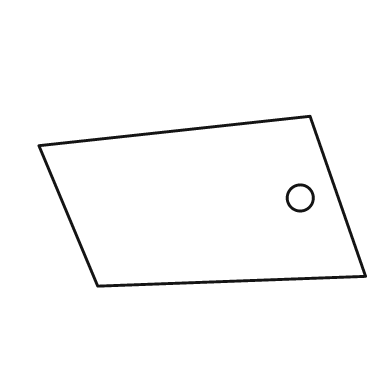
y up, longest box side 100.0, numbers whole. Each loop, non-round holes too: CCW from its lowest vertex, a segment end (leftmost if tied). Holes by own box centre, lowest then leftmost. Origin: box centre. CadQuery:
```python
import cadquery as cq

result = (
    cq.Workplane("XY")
    .moveTo(-32.0, -26.0)
    .lineTo(50.0, -23.0)
    .lineTo(33.0, 26.0)
    .lineTo(-50.0, 17.0)
    .close()
    .moveTo(30.0, 1.0)
    .circle(4.0)
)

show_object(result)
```